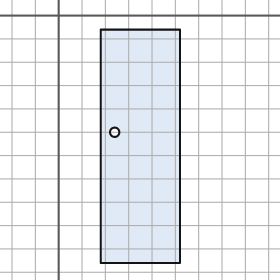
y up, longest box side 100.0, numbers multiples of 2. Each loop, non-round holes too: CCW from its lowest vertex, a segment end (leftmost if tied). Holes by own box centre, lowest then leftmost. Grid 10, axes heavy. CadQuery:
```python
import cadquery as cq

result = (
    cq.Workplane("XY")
    .moveTo(18.0, -106.0)
    .lineTo(52.0, -106.0)
    .lineTo(52.0, -6.0)
    .lineTo(18.0, -6.0)
    .close()
    .moveTo(24.0, -50.0)
    .circle(2.0)
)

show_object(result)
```